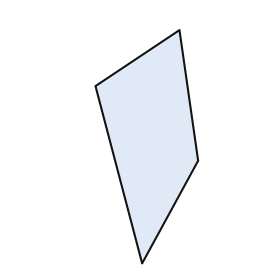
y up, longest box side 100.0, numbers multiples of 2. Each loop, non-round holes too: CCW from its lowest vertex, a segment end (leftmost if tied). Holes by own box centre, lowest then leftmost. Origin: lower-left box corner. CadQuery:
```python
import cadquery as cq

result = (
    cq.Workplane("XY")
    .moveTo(20.0, 0.0)
    .lineTo(44.0, 44.0)
    .lineTo(36.0, 100.0)
    .lineTo(0.0, 76.0)
    .close()
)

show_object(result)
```